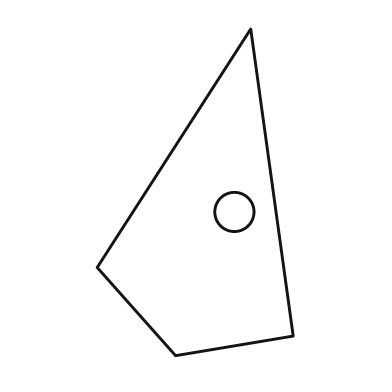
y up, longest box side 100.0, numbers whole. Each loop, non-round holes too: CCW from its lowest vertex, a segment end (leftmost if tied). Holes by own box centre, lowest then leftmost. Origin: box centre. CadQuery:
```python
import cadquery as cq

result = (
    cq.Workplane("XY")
    .moveTo(-6.0, -50.0)
    .lineTo(30.0, -44.0)
    .lineTo(17.0, 50.0)
    .lineTo(-30.0, -23.0)
    .close()
    .moveTo(12.0, -6.0)
    .circle(6.0)
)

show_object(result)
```